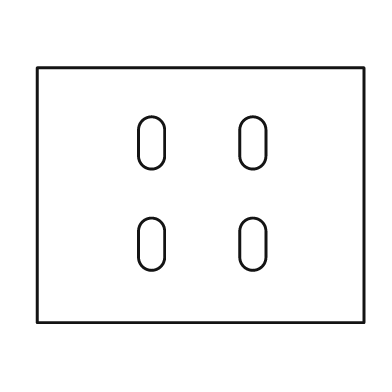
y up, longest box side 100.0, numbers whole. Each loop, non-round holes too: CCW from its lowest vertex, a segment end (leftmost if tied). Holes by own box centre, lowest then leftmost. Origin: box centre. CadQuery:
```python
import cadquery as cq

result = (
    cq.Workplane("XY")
    .moveTo(-50.0, -39.0)
    .lineTo(50.0, -39.0)
    .lineTo(50.0, 39.0)
    .lineTo(-50.0, 39.0)
    .close()
    .moveTo(-19.0, -19.0)
    .threePointArc((-15.0, -23.0), (-11.0, -19.0))
    .lineTo(-11.0, -11.0)
    .threePointArc((-15.0, -7.0), (-19.0, -11.0))
    .close()
    .moveTo(12.0, -19.0)
    .threePointArc((16.0, -23.0), (20.0, -19.0))
    .lineTo(20.0, -11.0)
    .threePointArc((16.0, -7.0), (12.0, -11.0))
    .close()
    .moveTo(-19.0, 12.0)
    .threePointArc((-15.0, 8.0), (-11.0, 12.0))
    .lineTo(-11.0, 20.0)
    .threePointArc((-15.0, 24.0), (-19.0, 20.0))
    .close()
    .moveTo(12.0, 12.0)
    .threePointArc((16.0, 8.0), (20.0, 12.0))
    .lineTo(20.0, 20.0)
    .threePointArc((16.0, 24.0), (12.0, 20.0))
    .close()
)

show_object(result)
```